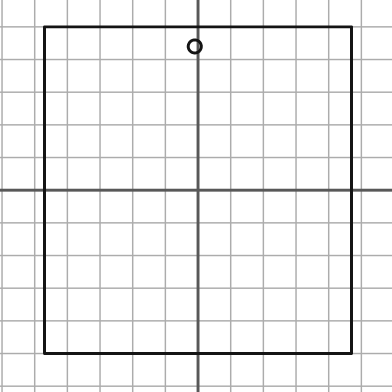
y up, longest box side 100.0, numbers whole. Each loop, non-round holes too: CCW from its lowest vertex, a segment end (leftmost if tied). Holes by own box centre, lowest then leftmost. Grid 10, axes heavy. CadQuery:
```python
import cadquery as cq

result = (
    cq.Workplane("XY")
    .moveTo(-47.0, -50.0)
    .lineTo(47.0, -50.0)
    .lineTo(47.0, 50.0)
    .lineTo(-47.0, 50.0)
    .close()
    .moveTo(-1.0, 44.0)
    .circle(2.0)
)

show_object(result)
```